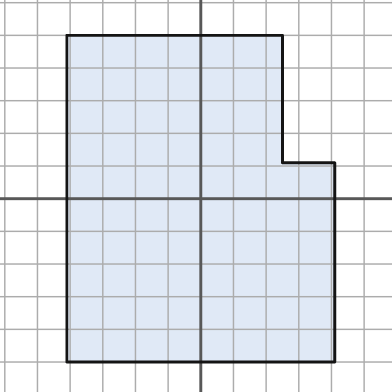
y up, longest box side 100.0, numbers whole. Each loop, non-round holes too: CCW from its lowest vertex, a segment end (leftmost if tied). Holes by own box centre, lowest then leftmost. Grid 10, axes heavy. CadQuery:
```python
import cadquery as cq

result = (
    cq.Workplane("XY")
    .moveTo(-41.0, -50.0)
    .lineTo(41.0, -50.0)
    .lineTo(41.0, 11.0)
    .lineTo(25.0, 11.0)
    .lineTo(25.0, 50.0)
    .lineTo(-41.0, 50.0)
    .close()
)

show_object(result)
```